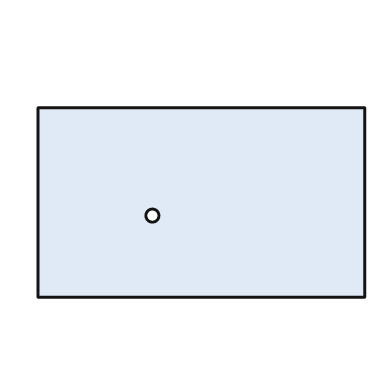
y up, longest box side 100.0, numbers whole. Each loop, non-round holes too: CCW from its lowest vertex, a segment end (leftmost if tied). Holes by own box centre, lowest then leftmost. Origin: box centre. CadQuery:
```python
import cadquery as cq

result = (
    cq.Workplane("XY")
    .moveTo(-50.0, -29.0)
    .lineTo(50.0, -29.0)
    .lineTo(50.0, 29.0)
    .lineTo(-50.0, 29.0)
    .close()
    .moveTo(-15.0, -4.0)
    .circle(2.0)
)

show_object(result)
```